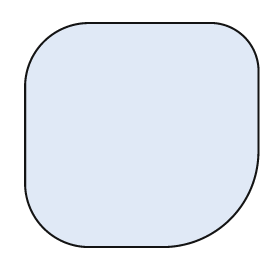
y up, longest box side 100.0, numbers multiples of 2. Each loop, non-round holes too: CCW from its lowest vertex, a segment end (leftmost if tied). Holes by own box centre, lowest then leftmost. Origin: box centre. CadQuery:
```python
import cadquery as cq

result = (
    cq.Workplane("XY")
    .moveTo(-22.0, -48.0)
    .lineTo(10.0, -48.0)
    .threePointArc((38.0, -36.0), (50.0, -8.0))
    .lineTo(50.0, 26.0)
    .threePointArc((44.0, 42.0), (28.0, 48.0))
    .lineTo(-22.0, 48.0)
    .threePointArc((-42.0, 40.0), (-50.0, 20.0))
    .lineTo(-50.0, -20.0)
    .threePointArc((-42.0, -40.0), (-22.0, -48.0))
    .close()
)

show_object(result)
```